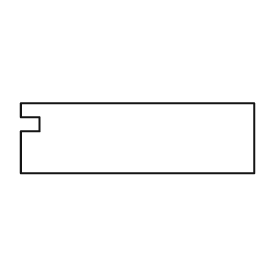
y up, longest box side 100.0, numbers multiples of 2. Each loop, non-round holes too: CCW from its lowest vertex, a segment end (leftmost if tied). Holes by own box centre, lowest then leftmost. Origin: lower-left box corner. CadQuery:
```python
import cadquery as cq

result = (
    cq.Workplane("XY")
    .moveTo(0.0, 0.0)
    .lineTo(100.0, 0.0)
    .lineTo(100.0, 30.0)
    .lineTo(0.0, 30.0)
    .lineTo(0.0, 24.0)
    .lineTo(8.0, 24.0)
    .lineTo(8.0, 18.0)
    .lineTo(0.0, 18.0)
    .close()
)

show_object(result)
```